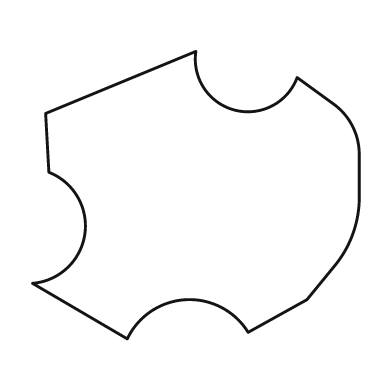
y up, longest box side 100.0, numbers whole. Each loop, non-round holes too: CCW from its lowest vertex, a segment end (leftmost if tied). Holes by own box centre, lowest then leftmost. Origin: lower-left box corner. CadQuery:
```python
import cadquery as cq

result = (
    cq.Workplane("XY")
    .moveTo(29.0, 0.0)
    .threePointArc((47.0, 12.0), (66.0, 2.0))
    .lineTo(84.0, 12.0)
    .lineTo(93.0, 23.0)
    .threePointArc((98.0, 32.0), (100.0, 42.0))
    .lineTo(100.0, 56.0)
    .threePointArc((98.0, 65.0), (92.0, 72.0))
    .lineTo(81.0, 80.0)
    .threePointArc((62.0, 70.0), (50.0, 88.0))
    .lineTo(4.0, 69.0)
    .lineTo(5.0, 51.0)
    .threePointArc((16.0, 32.0), (0.0, 17.0))
    .close()
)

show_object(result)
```